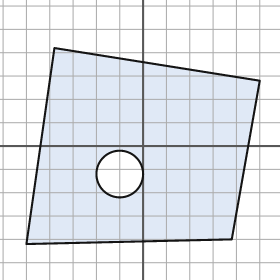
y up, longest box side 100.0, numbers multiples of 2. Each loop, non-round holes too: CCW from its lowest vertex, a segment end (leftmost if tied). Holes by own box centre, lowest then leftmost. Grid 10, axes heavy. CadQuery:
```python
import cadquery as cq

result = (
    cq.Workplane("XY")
    .moveTo(-50.0, -42.0)
    .lineTo(38.0, -40.0)
    .lineTo(50.0, 28.0)
    .lineTo(-38.0, 42.0)
    .close()
    .moveTo(-10.0, -12.0)
    .circle(10.0)
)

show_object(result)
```